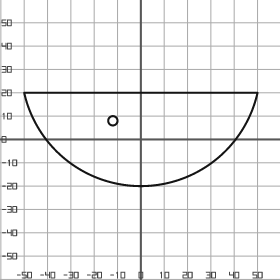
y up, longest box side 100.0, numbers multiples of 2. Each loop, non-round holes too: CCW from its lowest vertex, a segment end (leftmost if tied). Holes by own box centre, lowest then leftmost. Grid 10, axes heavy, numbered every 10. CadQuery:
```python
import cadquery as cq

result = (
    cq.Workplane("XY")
    .moveTo(-50.0, 20.0)
    .threePointArc((0.0, -20.0), (50.0, 20.0))
    .close()
    .moveTo(-12.0, 8.0)
    .circle(2.0)
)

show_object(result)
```